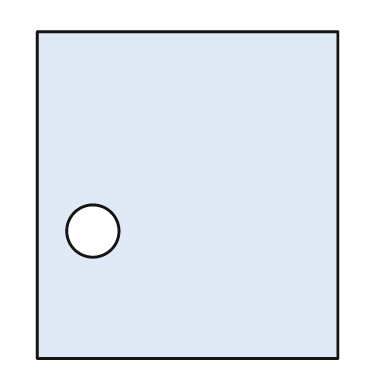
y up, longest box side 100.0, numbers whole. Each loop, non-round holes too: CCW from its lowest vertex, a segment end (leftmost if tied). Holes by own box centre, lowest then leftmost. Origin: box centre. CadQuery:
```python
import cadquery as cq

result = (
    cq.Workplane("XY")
    .moveTo(-46.0, -50.0)
    .lineTo(46.0, -50.0)
    .lineTo(46.0, 50.0)
    .lineTo(-46.0, 50.0)
    .close()
    .moveTo(-29.0, -11.0)
    .circle(8.0)
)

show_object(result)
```